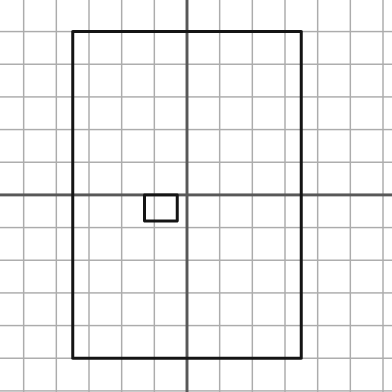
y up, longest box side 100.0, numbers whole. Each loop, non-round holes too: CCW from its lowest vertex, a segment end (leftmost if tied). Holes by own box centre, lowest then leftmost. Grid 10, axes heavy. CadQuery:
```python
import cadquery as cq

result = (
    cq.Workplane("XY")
    .moveTo(-35.0, -50.0)
    .lineTo(35.0, -50.0)
    .lineTo(35.0, 50.0)
    .lineTo(-35.0, 50.0)
    .close()
    .moveTo(-13.0, -8.0)
    .lineTo(-3.0, -8.0)
    .lineTo(-3.0, 0.0)
    .lineTo(-13.0, 0.0)
    .close()
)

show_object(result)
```